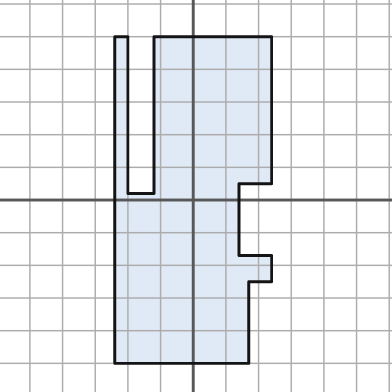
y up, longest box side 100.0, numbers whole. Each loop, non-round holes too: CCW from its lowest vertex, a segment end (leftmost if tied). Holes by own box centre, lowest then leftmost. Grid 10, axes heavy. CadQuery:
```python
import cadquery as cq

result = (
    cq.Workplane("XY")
    .moveTo(-24.0, -50.0)
    .lineTo(17.0, -50.0)
    .lineTo(17.0, -25.0)
    .lineTo(24.0, -25.0)
    .lineTo(24.0, -17.0)
    .lineTo(14.0, -17.0)
    .lineTo(14.0, 5.0)
    .lineTo(24.0, 5.0)
    .lineTo(24.0, 50.0)
    .lineTo(-12.0, 50.0)
    .lineTo(-12.0, 2.0)
    .lineTo(-20.0, 2.0)
    .lineTo(-20.0, 50.0)
    .lineTo(-24.0, 50.0)
    .close()
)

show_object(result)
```